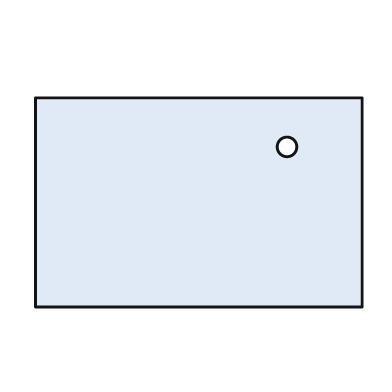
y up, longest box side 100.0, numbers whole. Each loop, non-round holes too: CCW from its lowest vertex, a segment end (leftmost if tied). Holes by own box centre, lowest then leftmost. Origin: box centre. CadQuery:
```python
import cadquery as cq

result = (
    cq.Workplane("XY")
    .moveTo(-50.0, -32.0)
    .lineTo(50.0, -32.0)
    .lineTo(50.0, 32.0)
    .lineTo(-50.0, 32.0)
    .close()
    .moveTo(27.0, 17.0)
    .circle(3.0)
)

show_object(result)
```